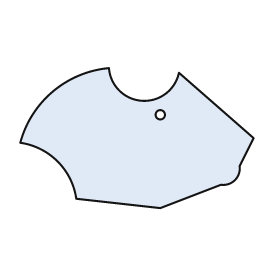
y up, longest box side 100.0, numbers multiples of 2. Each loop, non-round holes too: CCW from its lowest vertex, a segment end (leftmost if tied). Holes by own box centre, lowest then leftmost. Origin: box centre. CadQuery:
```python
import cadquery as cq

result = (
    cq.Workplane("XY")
    .moveTo(10.0, -30.0)
    .lineTo(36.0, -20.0)
    .threePointArc((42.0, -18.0), (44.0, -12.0))
    .lineTo(50.0, 0.0)
    .lineTo(18.0, 28.0)
    .threePointArc((2.0, 16.0), (-12.0, 30.0))
    .threePointArc((-36.0, 20.0), (-50.0, -2.0))
    .threePointArc((-34.0, -10.0), (-26.0, -26.0))
    .close()
    .moveTo(10.0, 10.0)
    .circle(2.0)
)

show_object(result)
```